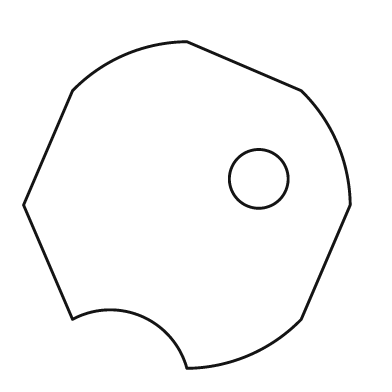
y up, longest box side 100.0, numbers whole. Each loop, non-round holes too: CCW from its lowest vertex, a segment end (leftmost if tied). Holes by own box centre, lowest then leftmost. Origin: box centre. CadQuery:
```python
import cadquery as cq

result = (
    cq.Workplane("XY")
    .moveTo(0.0, -50.0)
    .threePointArc((19.0, -46.0), (35.0, -35.0))
    .lineTo(50.0, 0.0)
    .threePointArc((46.0, 19.0), (35.0, 35.0))
    .lineTo(0.0, 50.0)
    .threePointArc((-19.0, 46.0), (-35.0, 35.0))
    .lineTo(-50.0, 0.0)
    .lineTo(-35.0, -35.0)
    .threePointArc((-14.0, -34.0), (0.0, -50.0))
    .close()
    .moveTo(22.0, 8.0)
    .circle(9.0)
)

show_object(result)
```